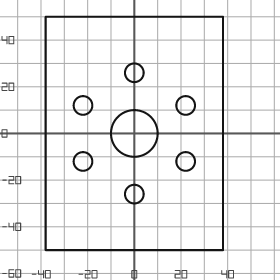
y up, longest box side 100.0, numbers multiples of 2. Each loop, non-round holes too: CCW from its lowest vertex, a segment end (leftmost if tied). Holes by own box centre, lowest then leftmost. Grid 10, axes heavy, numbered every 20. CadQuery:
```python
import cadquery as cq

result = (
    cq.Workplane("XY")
    .moveTo(-38.0, -50.0)
    .lineTo(38.0, -50.0)
    .lineTo(38.0, 50.0)
    .lineTo(-38.0, 50.0)
    .close()
    .moveTo(0.0, -26.0)
    .circle(4.0)
    .moveTo(-22.0, -12.0)
    .circle(4.0)
    .moveTo(22.0, -12.0)
    .circle(4.0)
    .moveTo(0.0, 0.0)
    .circle(10.0)
    .moveTo(-22.0, 12.0)
    .circle(4.0)
    .moveTo(22.0, 12.0)
    .circle(4.0)
    .moveTo(0.0, 26.0)
    .circle(4.0)
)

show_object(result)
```